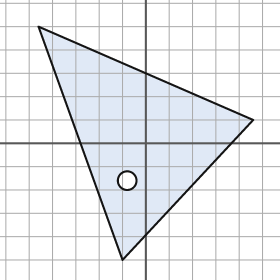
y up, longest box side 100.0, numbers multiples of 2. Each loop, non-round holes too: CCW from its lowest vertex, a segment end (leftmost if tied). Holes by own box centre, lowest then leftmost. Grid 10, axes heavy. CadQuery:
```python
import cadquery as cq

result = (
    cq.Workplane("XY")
    .moveTo(-10.0, -50.0)
    .lineTo(46.0, 10.0)
    .lineTo(-46.0, 50.0)
    .close()
    .moveTo(-8.0, -16.0)
    .circle(4.0)
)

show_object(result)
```